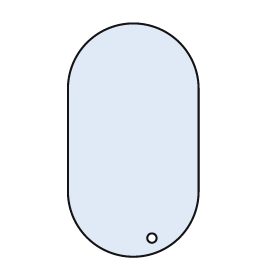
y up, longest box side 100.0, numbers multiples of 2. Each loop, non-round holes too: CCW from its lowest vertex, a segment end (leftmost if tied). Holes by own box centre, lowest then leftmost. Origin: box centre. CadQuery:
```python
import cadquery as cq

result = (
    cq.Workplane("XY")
    .moveTo(-28.0, -22.0)
    .threePointArc((0.0, -50.0), (28.0, -22.0))
    .lineTo(28.0, 22.0)
    .threePointArc((0.0, 50.0), (-28.0, 22.0))
    .close()
    .moveTo(8.0, -42.0)
    .circle(2.0)
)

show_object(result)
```